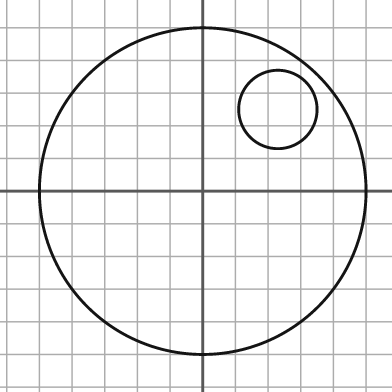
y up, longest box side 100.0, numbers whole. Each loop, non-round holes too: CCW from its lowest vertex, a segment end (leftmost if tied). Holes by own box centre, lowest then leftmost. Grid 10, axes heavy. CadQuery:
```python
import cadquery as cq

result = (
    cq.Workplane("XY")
    .moveTo(0.0, 0.0)
    .circle(50.0)
    .moveTo(23.0, 25.0)
    .circle(12.0)
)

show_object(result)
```